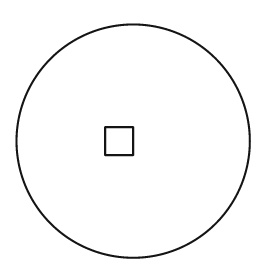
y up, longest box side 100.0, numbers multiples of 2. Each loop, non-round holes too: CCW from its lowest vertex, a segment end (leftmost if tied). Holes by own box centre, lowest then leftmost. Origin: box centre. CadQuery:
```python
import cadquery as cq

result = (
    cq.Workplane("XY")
    .moveTo(0.0, 0.0)
    .circle(50.0)
    .moveTo(-12.0, -6.0)
    .lineTo(0.0, -6.0)
    .lineTo(0.0, 6.0)
    .lineTo(-12.0, 6.0)
    .close()
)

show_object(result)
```